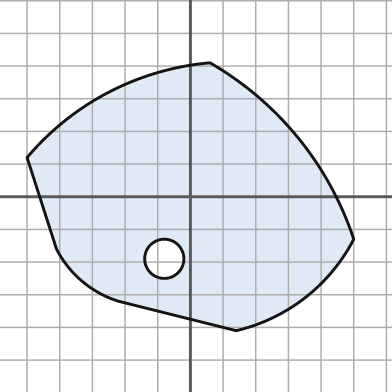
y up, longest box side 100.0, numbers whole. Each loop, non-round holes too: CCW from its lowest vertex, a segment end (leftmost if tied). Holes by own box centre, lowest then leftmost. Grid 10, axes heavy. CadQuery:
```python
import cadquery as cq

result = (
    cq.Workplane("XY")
    .moveTo(14.0, -41.0)
    .threePointArc((35.0, -31.0), (50.0, -13.0))
    .threePointArc((33.0, 18.0), (6.0, 41.0))
    .threePointArc((-25.0, 32.0), (-50.0, 12.0))
    .lineTo(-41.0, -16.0)
    .threePointArc((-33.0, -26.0), (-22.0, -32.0))
    .close()
    .moveTo(-8.0, -19.0)
    .circle(6.0)
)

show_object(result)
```